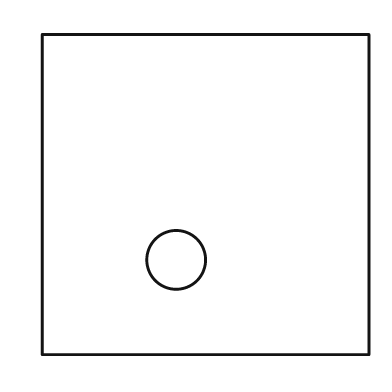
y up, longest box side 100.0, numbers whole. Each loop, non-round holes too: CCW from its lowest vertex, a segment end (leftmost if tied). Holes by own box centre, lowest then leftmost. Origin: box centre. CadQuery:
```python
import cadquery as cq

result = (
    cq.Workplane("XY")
    .moveTo(-50.0, -49.0)
    .lineTo(50.0, -49.0)
    .lineTo(50.0, 49.0)
    .lineTo(-50.0, 49.0)
    .close()
    .moveTo(-9.0, -20.0)
    .circle(9.0)
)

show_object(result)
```